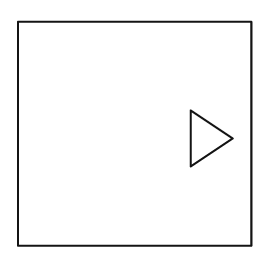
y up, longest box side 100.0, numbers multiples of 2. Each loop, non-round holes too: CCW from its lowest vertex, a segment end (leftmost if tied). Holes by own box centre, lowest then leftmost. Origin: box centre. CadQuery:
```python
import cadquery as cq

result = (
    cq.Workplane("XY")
    .moveTo(-50.0, -48.0)
    .lineTo(50.0, -48.0)
    .lineTo(50.0, 48.0)
    .lineTo(-50.0, 48.0)
    .close()
    .moveTo(24.0, -14.0)
    .lineTo(42.0, -2.0)
    .lineTo(24.0, 10.0)
    .close()
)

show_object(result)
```